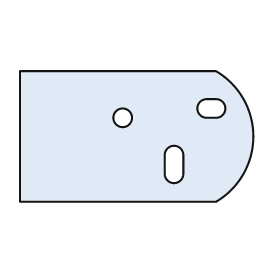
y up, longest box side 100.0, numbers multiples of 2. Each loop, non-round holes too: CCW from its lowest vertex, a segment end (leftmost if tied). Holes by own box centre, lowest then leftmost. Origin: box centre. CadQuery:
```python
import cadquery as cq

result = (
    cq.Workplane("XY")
    .moveTo(-50.0, -28.0)
    .lineTo(34.0, -28.0)
    .threePointArc((50.0, 0.0), (34.0, 28.0))
    .lineTo(-50.0, 28.0)
    .close()
    .moveTo(12.0, -16.0)
    .threePointArc((16.0, -20.0), (20.0, -16.0))
    .lineTo(20.0, -8.0)
    .threePointArc((16.0, -4.0), (12.0, -8.0))
    .close()
    .moveTo(-6.0, 8.0)
    .circle(4.0)
    .moveTo(30.0, 8.0)
    .lineTo(34.0, 8.0)
    .threePointArc((38.0, 12.0), (34.0, 16.0))
    .lineTo(30.0, 16.0)
    .threePointArc((26.0, 12.0), (30.0, 8.0))
    .close()
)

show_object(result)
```